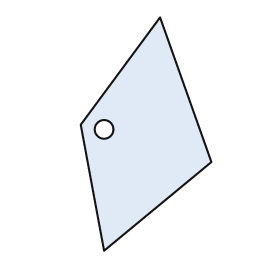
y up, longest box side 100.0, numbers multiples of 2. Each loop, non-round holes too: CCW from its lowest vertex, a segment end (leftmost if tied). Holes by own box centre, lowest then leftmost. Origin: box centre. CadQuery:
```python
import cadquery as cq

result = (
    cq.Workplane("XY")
    .moveTo(-18.0, -50.0)
    .lineTo(28.0, -12.0)
    .lineTo(6.0, 50.0)
    .lineTo(-28.0, 4.0)
    .close()
    .moveTo(-18.0, 2.0)
    .circle(4.0)
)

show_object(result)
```